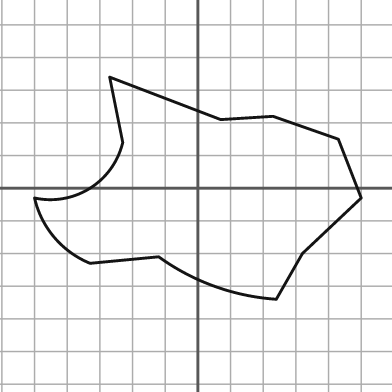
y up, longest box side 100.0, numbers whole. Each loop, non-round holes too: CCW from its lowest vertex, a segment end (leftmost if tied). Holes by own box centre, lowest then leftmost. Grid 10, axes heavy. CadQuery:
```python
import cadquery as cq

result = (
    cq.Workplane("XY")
    .moveTo(24.0, -34.0)
    .lineTo(32.0, -20.0)
    .lineTo(50.0, -3.0)
    .lineTo(43.0, 15.0)
    .lineTo(23.0, 22.0)
    .lineTo(7.0, 21.0)
    .lineTo(-27.0, 34.0)
    .lineTo(-23.0, 14.0)
    .threePointArc((-33.0, 0.0), (-50.0, -3.0))
    .threePointArc((-44.0, -15.0), (-33.0, -23.0))
    .lineTo(-12.0, -21.0)
    .threePointArc((5.0, -30.0), (24.0, -34.0))
    .close()
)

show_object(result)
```